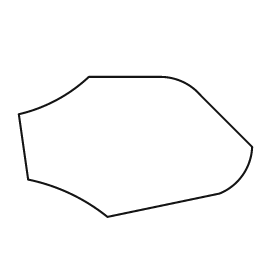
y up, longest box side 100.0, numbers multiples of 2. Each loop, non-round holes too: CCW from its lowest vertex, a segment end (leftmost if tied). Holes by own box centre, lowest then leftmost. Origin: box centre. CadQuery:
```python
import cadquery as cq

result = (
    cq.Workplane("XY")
    .moveTo(-12.0, -30.0)
    .lineTo(36.0, -20.0)
    .threePointArc((46.0, -12.0), (50.0, 0.0))
    .lineTo(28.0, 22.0)
    .threePointArc((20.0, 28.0), (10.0, 30.0))
    .lineTo(-20.0, 30.0)
    .threePointArc((-34.0, 20.0), (-50.0, 14.0))
    .lineTo(-46.0, -14.0)
    .threePointArc((-28.0, -20.0), (-12.0, -30.0))
    .close()
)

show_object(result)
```